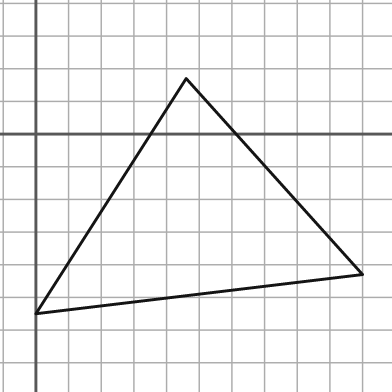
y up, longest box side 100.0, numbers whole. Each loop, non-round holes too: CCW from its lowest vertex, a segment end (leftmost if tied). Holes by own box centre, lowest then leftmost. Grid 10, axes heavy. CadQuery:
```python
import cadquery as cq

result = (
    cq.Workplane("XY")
    .moveTo(0.0, -55.0)
    .lineTo(100.0, -43.0)
    .lineTo(46.0, 17.0)
    .close()
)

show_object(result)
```